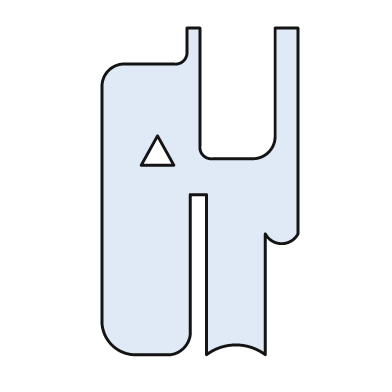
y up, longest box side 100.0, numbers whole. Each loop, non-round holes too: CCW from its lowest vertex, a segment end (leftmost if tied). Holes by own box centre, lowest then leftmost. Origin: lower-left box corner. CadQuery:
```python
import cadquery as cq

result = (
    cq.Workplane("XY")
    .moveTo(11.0, 0.0)
    .lineTo(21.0, 0.0)
    .threePointArc((25.0, 2.0), (27.0, 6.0))
    .lineTo(27.0, 49.0)
    .lineTo(32.0, 49.0)
    .lineTo(32.0, 0.0)
    .threePointArc((41.0, 3.0), (50.0, 0.0))
    .lineTo(50.0, 37.0)
    .threePointArc((55.0, 34.0), (60.0, 37.0))
    .lineTo(60.0, 100.0)
    .lineTo(53.0, 100.0)
    .lineTo(53.0, 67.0)
    .threePointArc((51.0, 62.0), (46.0, 60.0))
    .lineTo(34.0, 60.0)
    .threePointArc((31.0, 61.0), (30.0, 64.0))
    .lineTo(30.0, 100.0)
    .lineTo(26.0, 100.0)
    .lineTo(26.0, 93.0)
    .threePointArc((25.0, 90.0), (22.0, 89.0))
    .lineTo(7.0, 89.0)
    .threePointArc((2.0, 87.0), (0.0, 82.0))
    .lineTo(0.0, 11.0)
    .threePointArc((3.0, 3.0), (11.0, 0.0))
    .close()
    .moveTo(12.0, 58.0)
    .lineTo(22.0, 58.0)
    .lineTo(17.0, 67.0)
    .close()
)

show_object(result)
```